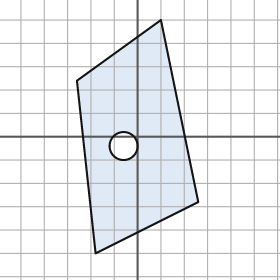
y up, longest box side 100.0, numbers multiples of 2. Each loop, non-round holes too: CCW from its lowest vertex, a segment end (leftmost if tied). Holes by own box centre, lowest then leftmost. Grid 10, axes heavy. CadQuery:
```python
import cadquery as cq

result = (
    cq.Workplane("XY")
    .moveTo(-18.0, -50.0)
    .lineTo(26.0, -28.0)
    .lineTo(10.0, 50.0)
    .lineTo(-26.0, 24.0)
    .close()
    .moveTo(-6.0, -4.0)
    .circle(6.0)
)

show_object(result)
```